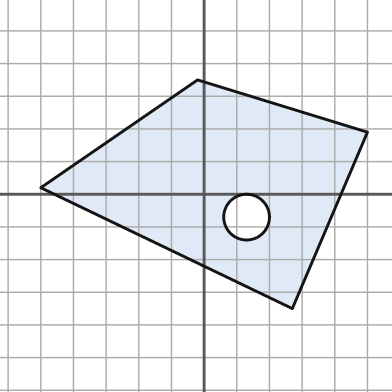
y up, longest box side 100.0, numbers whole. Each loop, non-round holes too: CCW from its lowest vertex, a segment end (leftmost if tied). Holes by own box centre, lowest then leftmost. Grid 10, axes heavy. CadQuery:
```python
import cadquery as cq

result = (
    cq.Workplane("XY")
    .moveTo(27.0, -35.0)
    .lineTo(50.0, 19.0)
    .lineTo(-2.0, 35.0)
    .lineTo(-50.0, 2.0)
    .close()
    .moveTo(13.0, -7.0)
    .circle(7.0)
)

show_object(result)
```